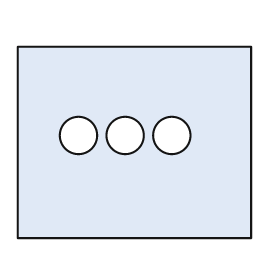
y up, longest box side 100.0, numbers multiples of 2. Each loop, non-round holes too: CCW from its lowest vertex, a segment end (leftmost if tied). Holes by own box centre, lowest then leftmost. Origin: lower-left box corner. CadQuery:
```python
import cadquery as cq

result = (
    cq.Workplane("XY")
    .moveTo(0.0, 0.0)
    .lineTo(100.0, 0.0)
    .lineTo(100.0, 82.0)
    .lineTo(0.0, 82.0)
    .close()
    .moveTo(26.0, 44.0)
    .circle(8.0)
    .moveTo(46.0, 44.0)
    .circle(8.0)
    .moveTo(66.0, 44.0)
    .circle(8.0)
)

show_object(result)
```